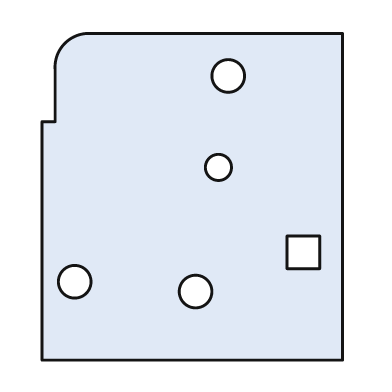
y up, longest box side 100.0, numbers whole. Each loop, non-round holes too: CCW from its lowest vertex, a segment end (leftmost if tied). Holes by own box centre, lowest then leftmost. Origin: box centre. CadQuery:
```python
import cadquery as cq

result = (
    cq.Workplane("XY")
    .moveTo(-46.0, -50.0)
    .lineTo(46.0, -50.0)
    .lineTo(46.0, 50.0)
    .lineTo(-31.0, 50.0)
    .threePointArc((-39.0, 47.0), (-42.0, 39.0))
    .lineTo(-42.0, 23.0)
    .lineTo(-46.0, 23.0)
    .close()
    .moveTo(1.0, -29.0)
    .circle(5.0)
    .moveTo(-36.0, -26.0)
    .circle(5.0)
    .moveTo(29.0, -22.0)
    .lineTo(39.0, -22.0)
    .lineTo(39.0, -12.0)
    .lineTo(29.0, -12.0)
    .close()
    .moveTo(8.0, 9.0)
    .circle(4.0)
    .moveTo(11.0, 37.0)
    .circle(5.0)
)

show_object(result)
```